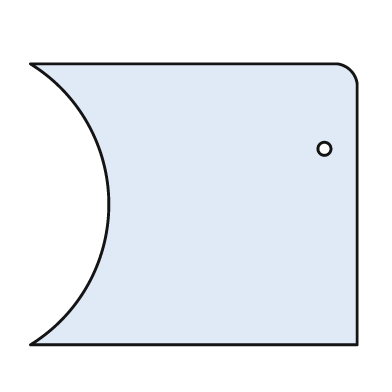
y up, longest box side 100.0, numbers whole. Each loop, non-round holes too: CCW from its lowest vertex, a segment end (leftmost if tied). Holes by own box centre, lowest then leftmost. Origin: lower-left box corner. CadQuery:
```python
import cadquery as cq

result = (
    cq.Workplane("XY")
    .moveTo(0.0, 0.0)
    .lineTo(100.0, 0.0)
    .lineTo(100.0, 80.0)
    .threePointArc((98.0, 84.0), (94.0, 86.0))
    .lineTo(0.0, 86.0)
    .threePointArc((24.0, 43.0), (0.0, 0.0))
    .close()
    .moveTo(90.0, 60.0)
    .circle(2.0)
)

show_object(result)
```